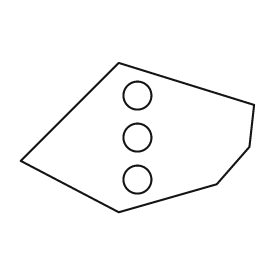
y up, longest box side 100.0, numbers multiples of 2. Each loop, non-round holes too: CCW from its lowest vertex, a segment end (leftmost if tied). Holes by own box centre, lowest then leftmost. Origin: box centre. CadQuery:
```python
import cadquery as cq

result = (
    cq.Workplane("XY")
    .moveTo(-8.0, -32.0)
    .lineTo(34.0, -20.0)
    .lineTo(48.0, -4.0)
    .lineTo(50.0, 14.0)
    .lineTo(-8.0, 32.0)
    .lineTo(-50.0, -10.0)
    .close()
    .moveTo(0.0, -18.0)
    .circle(6.0)
    .moveTo(0.0, 0.0)
    .circle(6.0)
    .moveTo(0.0, 18.0)
    .circle(6.0)
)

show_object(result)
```